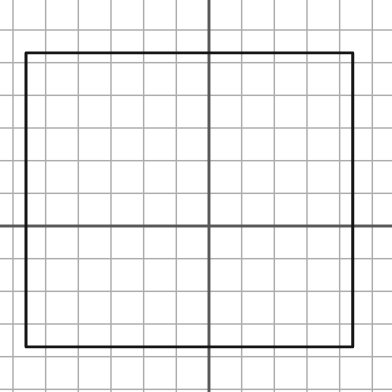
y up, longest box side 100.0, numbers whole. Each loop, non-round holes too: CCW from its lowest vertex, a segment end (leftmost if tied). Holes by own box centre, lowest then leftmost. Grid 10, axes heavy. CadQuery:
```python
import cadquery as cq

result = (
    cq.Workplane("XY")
    .moveTo(-56.0, -37.0)
    .lineTo(44.0, -37.0)
    .lineTo(44.0, 53.0)
    .lineTo(-56.0, 53.0)
    .close()
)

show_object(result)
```